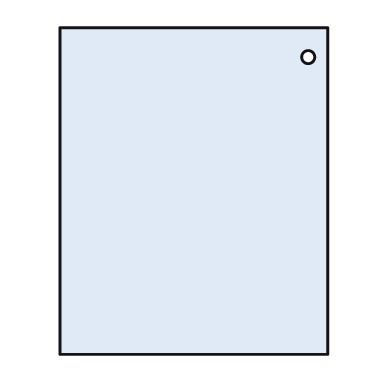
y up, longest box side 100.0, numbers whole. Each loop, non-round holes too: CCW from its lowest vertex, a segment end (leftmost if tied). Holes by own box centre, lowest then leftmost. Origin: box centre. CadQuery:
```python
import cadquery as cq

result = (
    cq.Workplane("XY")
    .moveTo(-41.0, -50.0)
    .lineTo(41.0, -50.0)
    .lineTo(41.0, 50.0)
    .lineTo(-41.0, 50.0)
    .close()
    .moveTo(35.0, 41.0)
    .circle(2.0)
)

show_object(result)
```